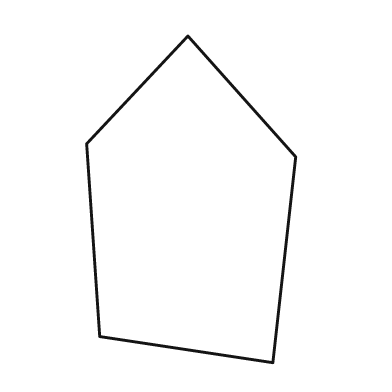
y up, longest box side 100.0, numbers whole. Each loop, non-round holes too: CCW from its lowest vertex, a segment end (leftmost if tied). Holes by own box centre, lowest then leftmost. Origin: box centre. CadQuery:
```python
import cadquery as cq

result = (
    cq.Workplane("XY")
    .moveTo(25.0, -50.0)
    .lineTo(32.0, 13.0)
    .lineTo(-1.0, 50.0)
    .lineTo(-32.0, 17.0)
    .lineTo(-28.0, -42.0)
    .close()
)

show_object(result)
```